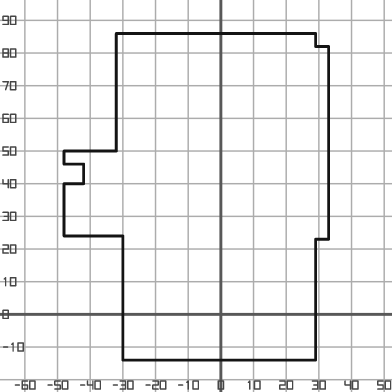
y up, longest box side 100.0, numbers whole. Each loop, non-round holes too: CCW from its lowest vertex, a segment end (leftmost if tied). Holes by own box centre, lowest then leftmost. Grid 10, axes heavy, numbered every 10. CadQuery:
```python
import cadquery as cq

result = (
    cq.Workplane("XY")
    .moveTo(-30.0, -14.0)
    .lineTo(29.0, -14.0)
    .lineTo(29.0, 23.0)
    .lineTo(33.0, 23.0)
    .lineTo(33.0, 82.0)
    .lineTo(29.0, 82.0)
    .lineTo(29.0, 86.0)
    .lineTo(-32.0, 86.0)
    .lineTo(-32.0, 50.0)
    .lineTo(-48.0, 50.0)
    .lineTo(-48.0, 46.0)
    .lineTo(-42.0, 46.0)
    .lineTo(-42.0, 40.0)
    .lineTo(-48.0, 40.0)
    .lineTo(-48.0, 24.0)
    .lineTo(-30.0, 24.0)
    .close()
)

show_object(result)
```